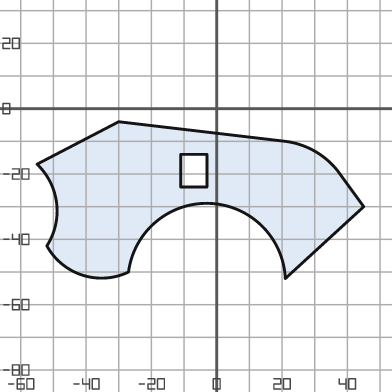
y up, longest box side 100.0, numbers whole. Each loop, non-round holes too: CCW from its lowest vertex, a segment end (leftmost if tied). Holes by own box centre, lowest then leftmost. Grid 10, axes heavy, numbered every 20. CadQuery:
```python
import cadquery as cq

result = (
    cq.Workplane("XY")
    .moveTo(21.0, -52.0)
    .lineTo(45.0, -30.0)
    .lineTo(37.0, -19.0)
    .threePointArc((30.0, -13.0), (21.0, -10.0))
    .lineTo(-30.0, -4.0)
    .lineTo(-55.0, -17.0)
    .threePointArc((-49.0, -29.0), (-52.0, -42.0))
    .threePointArc((-41.0, -51.0), (-27.0, -50.0))
    .threePointArc((-2.0, -29.0), (21.0, -52.0))
    .close()
    .moveTo(-11.0, -24.0)
    .lineTo(-3.0, -24.0)
    .lineTo(-3.0, -14.0)
    .lineTo(-11.0, -14.0)
    .close()
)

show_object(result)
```